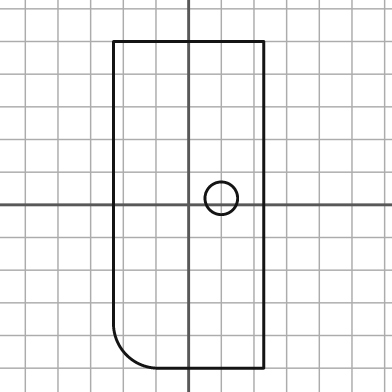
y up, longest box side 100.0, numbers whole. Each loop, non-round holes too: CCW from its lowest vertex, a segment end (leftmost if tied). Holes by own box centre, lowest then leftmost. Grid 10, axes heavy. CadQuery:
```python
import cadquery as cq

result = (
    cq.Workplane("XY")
    .moveTo(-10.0, -50.0)
    .lineTo(23.0, -50.0)
    .lineTo(23.0, 50.0)
    .lineTo(-23.0, 50.0)
    .lineTo(-23.0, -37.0)
    .threePointArc((-19.0, -46.0), (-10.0, -50.0))
    .close()
    .moveTo(10.0, 2.0)
    .circle(5.0)
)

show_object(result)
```